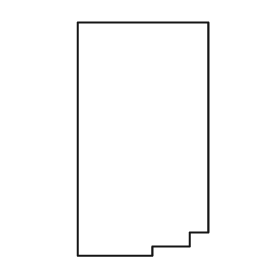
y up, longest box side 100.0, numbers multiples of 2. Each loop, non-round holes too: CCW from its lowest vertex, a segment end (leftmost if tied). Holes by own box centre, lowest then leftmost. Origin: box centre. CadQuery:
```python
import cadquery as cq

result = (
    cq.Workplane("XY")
    .moveTo(-28.0, -50.0)
    .lineTo(4.0, -50.0)
    .lineTo(4.0, -46.0)
    .lineTo(20.0, -46.0)
    .lineTo(20.0, -40.0)
    .lineTo(28.0, -40.0)
    .lineTo(28.0, 50.0)
    .lineTo(-28.0, 50.0)
    .close()
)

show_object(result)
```